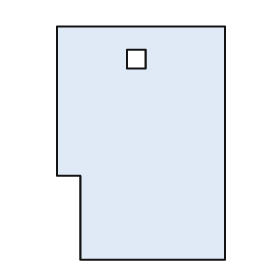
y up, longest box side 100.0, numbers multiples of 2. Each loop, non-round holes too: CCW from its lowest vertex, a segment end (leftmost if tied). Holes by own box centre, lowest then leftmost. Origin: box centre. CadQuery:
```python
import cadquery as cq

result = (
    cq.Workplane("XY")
    .moveTo(-26.0, -50.0)
    .lineTo(36.0, -50.0)
    .lineTo(36.0, 50.0)
    .lineTo(-36.0, 50.0)
    .lineTo(-36.0, -14.0)
    .lineTo(-26.0, -14.0)
    .close()
    .moveTo(-6.0, 32.0)
    .lineTo(2.0, 32.0)
    .lineTo(2.0, 40.0)
    .lineTo(-6.0, 40.0)
    .close()
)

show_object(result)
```